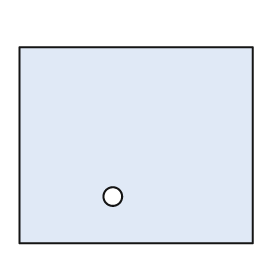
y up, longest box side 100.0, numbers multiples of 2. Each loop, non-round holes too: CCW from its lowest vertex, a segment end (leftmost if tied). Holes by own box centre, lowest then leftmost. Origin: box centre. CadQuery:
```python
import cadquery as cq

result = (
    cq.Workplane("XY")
    .moveTo(-50.0, -42.0)
    .lineTo(50.0, -42.0)
    .lineTo(50.0, 42.0)
    .lineTo(-50.0, 42.0)
    .close()
    .moveTo(-10.0, -22.0)
    .circle(4.0)
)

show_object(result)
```